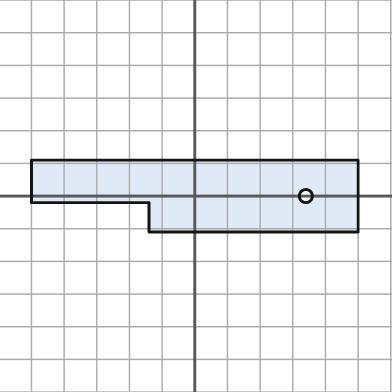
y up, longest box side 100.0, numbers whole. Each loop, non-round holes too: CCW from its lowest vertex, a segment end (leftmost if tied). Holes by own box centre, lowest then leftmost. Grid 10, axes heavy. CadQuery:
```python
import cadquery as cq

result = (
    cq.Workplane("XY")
    .moveTo(-14.0, -11.0)
    .lineTo(50.0, -11.0)
    .lineTo(50.0, 11.0)
    .lineTo(-50.0, 11.0)
    .lineTo(-50.0, -2.0)
    .lineTo(-14.0, -2.0)
    .close()
    .moveTo(34.0, 0.0)
    .circle(2.0)
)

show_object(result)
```